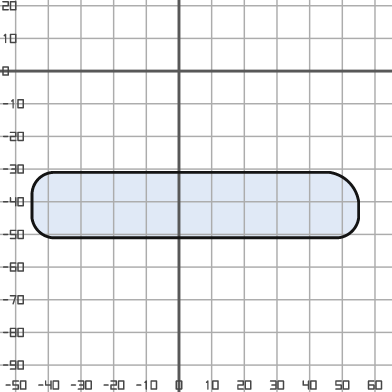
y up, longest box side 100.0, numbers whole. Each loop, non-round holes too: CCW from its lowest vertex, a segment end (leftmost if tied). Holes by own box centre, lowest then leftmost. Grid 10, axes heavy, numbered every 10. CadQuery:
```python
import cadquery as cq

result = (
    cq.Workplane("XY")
    .moveTo(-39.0, -51.0)
    .lineTo(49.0, -51.0)
    .threePointArc((53.0, -49.0), (55.0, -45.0))
    .lineTo(55.0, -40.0)
    .threePointArc((52.0, -34.0), (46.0, -31.0))
    .lineTo(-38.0, -31.0)
    .threePointArc((-43.0, -33.0), (-45.0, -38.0))
    .lineTo(-45.0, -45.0)
    .threePointArc((-43.0, -49.0), (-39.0, -51.0))
    .close()
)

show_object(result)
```